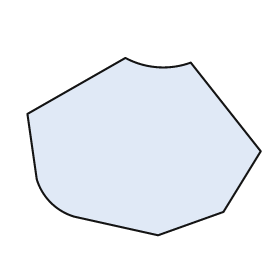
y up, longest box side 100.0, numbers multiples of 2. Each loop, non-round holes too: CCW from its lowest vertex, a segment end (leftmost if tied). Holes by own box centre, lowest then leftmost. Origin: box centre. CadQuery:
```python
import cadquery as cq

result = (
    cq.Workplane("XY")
    .moveTo(6.0, -38.0)
    .lineTo(34.0, -28.0)
    .lineTo(50.0, -2.0)
    .lineTo(20.0, 36.0)
    .threePointArc((6.0, 34.0), (-8.0, 38.0))
    .lineTo(-50.0, 14.0)
    .lineTo(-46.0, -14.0)
    .threePointArc((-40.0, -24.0), (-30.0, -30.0))
    .close()
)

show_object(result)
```